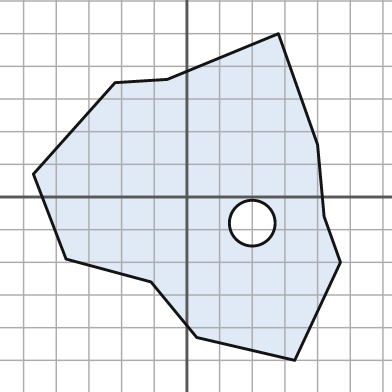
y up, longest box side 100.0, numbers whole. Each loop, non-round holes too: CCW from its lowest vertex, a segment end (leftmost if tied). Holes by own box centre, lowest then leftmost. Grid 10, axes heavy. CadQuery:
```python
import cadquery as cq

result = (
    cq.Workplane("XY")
    .moveTo(33.0, -50.0)
    .lineTo(47.0, -20.0)
    .lineTo(42.0, -6.0)
    .lineTo(40.0, 16.0)
    .lineTo(28.0, 50.0)
    .lineTo(-6.0, 36.0)
    .lineTo(-22.0, 35.0)
    .lineTo(-47.0, 7.0)
    .lineTo(-37.0, -19.0)
    .lineTo(-11.0, -26.0)
    .lineTo(3.0, -43.0)
    .close()
    .moveTo(20.0, -8.0)
    .circle(7.0)
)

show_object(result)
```